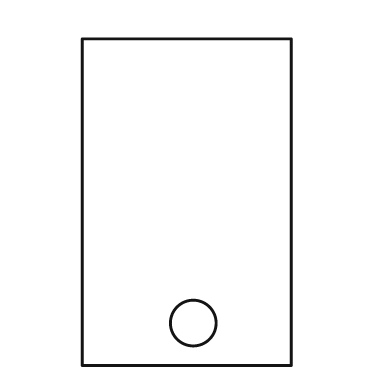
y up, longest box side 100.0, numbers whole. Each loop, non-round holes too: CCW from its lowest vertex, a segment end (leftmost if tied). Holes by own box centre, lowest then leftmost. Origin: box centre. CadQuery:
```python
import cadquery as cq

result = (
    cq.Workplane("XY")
    .moveTo(-32.0, -50.0)
    .lineTo(32.0, -50.0)
    .lineTo(32.0, 50.0)
    .lineTo(-32.0, 50.0)
    .close()
    .moveTo(2.0, -37.0)
    .circle(7.0)
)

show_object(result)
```